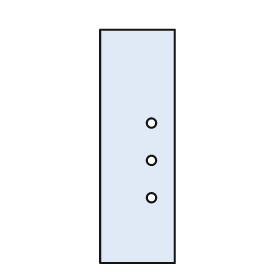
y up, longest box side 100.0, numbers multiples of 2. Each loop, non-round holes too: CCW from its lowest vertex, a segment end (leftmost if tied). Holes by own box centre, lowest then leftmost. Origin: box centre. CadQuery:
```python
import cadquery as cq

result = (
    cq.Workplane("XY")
    .moveTo(-16.0, -50.0)
    .lineTo(16.0, -50.0)
    .lineTo(16.0, 50.0)
    .lineTo(-16.0, 50.0)
    .close()
    .moveTo(6.0, -22.0)
    .circle(2.0)
    .moveTo(6.0, -6.0)
    .circle(2.0)
    .moveTo(6.0, 10.0)
    .circle(2.0)
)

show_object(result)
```